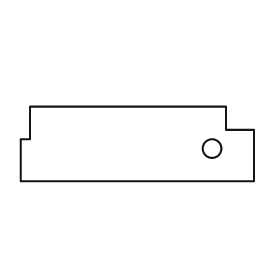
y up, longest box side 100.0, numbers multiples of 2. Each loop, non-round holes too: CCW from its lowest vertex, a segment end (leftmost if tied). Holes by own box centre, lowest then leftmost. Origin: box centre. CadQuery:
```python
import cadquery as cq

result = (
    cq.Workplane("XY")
    .moveTo(-50.0, -16.0)
    .lineTo(50.0, -16.0)
    .lineTo(50.0, 6.0)
    .lineTo(38.0, 6.0)
    .lineTo(38.0, 16.0)
    .lineTo(-46.0, 16.0)
    .lineTo(-46.0, 2.0)
    .lineTo(-50.0, 2.0)
    .close()
    .moveTo(32.0, -2.0)
    .circle(4.0)
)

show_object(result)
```